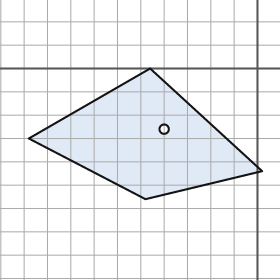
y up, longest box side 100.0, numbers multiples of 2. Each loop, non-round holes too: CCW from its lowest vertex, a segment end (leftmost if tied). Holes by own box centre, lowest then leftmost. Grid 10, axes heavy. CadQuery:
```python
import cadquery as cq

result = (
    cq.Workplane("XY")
    .moveTo(-48.0, -56.0)
    .lineTo(2.0, -44.0)
    .lineTo(-46.0, 0.0)
    .lineTo(-98.0, -30.0)
    .close()
    .moveTo(-40.0, -26.0)
    .circle(2.0)
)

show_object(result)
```